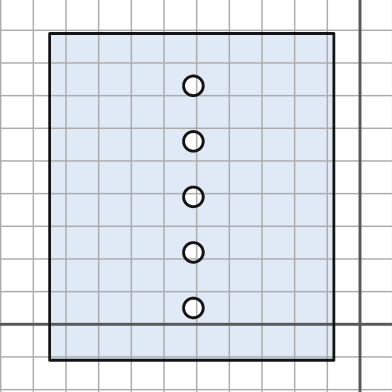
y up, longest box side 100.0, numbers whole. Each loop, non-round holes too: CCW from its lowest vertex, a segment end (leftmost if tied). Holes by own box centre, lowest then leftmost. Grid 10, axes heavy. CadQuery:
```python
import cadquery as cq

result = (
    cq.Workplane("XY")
    .moveTo(-95.0, -11.0)
    .lineTo(-8.0, -11.0)
    .lineTo(-8.0, 89.0)
    .lineTo(-95.0, 89.0)
    .close()
    .moveTo(-51.0, 5.0)
    .circle(3.0)
    .moveTo(-51.0, 22.0)
    .circle(3.0)
    .moveTo(-51.0, 39.0)
    .circle(3.0)
    .moveTo(-51.0, 56.0)
    .circle(3.0)
    .moveTo(-51.0, 73.0)
    .circle(3.0)
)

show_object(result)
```